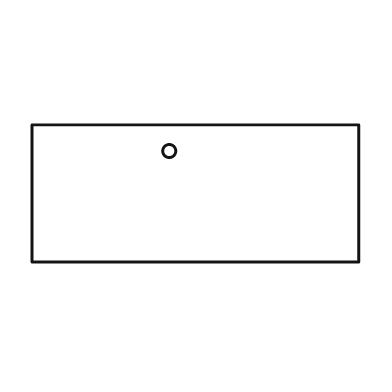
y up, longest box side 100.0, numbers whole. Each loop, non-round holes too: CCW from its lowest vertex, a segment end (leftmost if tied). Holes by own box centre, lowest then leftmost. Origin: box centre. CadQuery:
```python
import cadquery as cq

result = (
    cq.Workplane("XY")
    .moveTo(-50.0, -21.0)
    .lineTo(50.0, -21.0)
    .lineTo(50.0, 21.0)
    .lineTo(-50.0, 21.0)
    .close()
    .moveTo(-8.0, 13.0)
    .circle(2.0)
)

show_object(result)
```